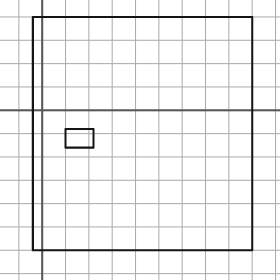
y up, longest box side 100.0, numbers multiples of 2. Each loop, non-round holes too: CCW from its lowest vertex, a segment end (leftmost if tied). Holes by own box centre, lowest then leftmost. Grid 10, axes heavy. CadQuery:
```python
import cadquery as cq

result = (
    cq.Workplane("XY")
    .moveTo(-4.0, -60.0)
    .lineTo(90.0, -60.0)
    .lineTo(90.0, 40.0)
    .lineTo(-4.0, 40.0)
    .close()
    .moveTo(10.0, -16.0)
    .lineTo(22.0, -16.0)
    .lineTo(22.0, -8.0)
    .lineTo(10.0, -8.0)
    .close()
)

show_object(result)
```